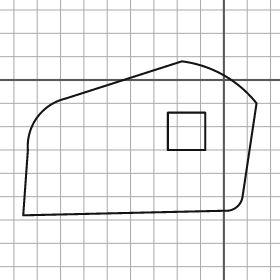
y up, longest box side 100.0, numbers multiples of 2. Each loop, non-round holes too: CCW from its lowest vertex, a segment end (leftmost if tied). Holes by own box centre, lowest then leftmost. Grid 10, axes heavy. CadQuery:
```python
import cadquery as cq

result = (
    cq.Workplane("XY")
    .moveTo(-86.0, -58.0)
    .lineTo(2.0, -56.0)
    .threePointArc((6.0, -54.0), (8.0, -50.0))
    .lineTo(14.0, -10.0)
    .threePointArc((0.0, 2.0), (-18.0, 8.0))
    .lineTo(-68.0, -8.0)
    .threePointArc((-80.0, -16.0), (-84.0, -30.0))
    .close()
    .moveTo(-24.0, -30.0)
    .lineTo(-8.0, -30.0)
    .lineTo(-8.0, -14.0)
    .lineTo(-24.0, -14.0)
    .close()
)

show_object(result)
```